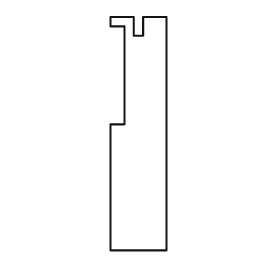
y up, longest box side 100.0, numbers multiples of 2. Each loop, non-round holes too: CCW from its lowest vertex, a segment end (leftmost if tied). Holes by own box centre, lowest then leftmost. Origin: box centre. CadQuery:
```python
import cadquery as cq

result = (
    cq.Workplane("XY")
    .moveTo(-12.0, -50.0)
    .lineTo(12.0, -50.0)
    .lineTo(12.0, 50.0)
    .lineTo(2.0, 50.0)
    .lineTo(2.0, 42.0)
    .lineTo(-2.0, 42.0)
    .lineTo(-2.0, 50.0)
    .lineTo(-12.0, 50.0)
    .lineTo(-12.0, 46.0)
    .lineTo(-6.0, 46.0)
    .lineTo(-6.0, 4.0)
    .lineTo(-12.0, 4.0)
    .close()
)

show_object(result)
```